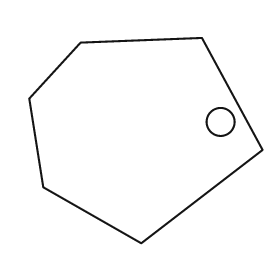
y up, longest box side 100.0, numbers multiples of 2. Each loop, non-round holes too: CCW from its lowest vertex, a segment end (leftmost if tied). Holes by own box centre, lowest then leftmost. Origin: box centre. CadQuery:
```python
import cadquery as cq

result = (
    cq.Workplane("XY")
    .moveTo(-2.0, -44.0)
    .lineTo(50.0, -4.0)
    .lineTo(24.0, 44.0)
    .lineTo(-28.0, 42.0)
    .lineTo(-50.0, 18.0)
    .lineTo(-44.0, -20.0)
    .close()
    .moveTo(32.0, 8.0)
    .circle(6.0)
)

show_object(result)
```